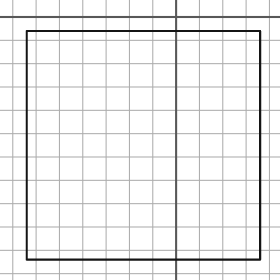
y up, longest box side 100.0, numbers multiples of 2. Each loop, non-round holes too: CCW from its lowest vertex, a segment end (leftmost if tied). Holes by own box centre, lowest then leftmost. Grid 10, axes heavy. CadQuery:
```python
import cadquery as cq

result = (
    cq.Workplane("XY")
    .moveTo(-64.0, -104.0)
    .lineTo(36.0, -104.0)
    .lineTo(36.0, -6.0)
    .lineTo(-64.0, -6.0)
    .close()
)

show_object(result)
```